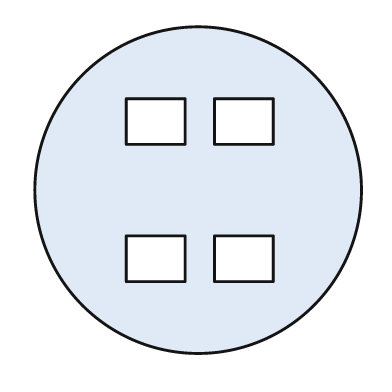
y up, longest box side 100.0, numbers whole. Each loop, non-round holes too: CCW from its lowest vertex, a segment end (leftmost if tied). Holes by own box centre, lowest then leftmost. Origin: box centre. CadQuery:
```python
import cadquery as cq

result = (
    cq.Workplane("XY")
    .moveTo(0.0, 0.0)
    .circle(50.0)
    .moveTo(-22.0, -28.0)
    .lineTo(-4.0, -28.0)
    .lineTo(-4.0, -14.0)
    .lineTo(-22.0, -14.0)
    .close()
    .moveTo(5.0, -28.0)
    .lineTo(23.0, -28.0)
    .lineTo(23.0, -14.0)
    .lineTo(5.0, -14.0)
    .close()
    .moveTo(-22.0, 14.0)
    .lineTo(-4.0, 14.0)
    .lineTo(-4.0, 28.0)
    .lineTo(-22.0, 28.0)
    .close()
    .moveTo(5.0, 14.0)
    .lineTo(23.0, 14.0)
    .lineTo(23.0, 28.0)
    .lineTo(5.0, 28.0)
    .close()
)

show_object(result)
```